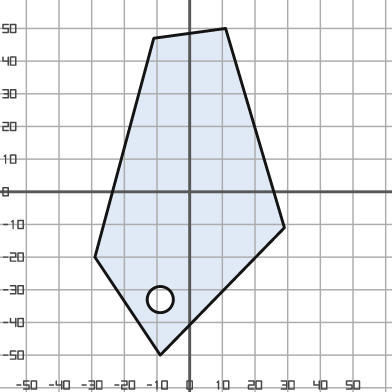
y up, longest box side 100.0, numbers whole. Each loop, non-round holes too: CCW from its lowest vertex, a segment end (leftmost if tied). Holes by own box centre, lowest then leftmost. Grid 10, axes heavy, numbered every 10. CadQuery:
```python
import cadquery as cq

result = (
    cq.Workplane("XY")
    .moveTo(-9.0, -50.0)
    .lineTo(29.0, -11.0)
    .lineTo(11.0, 50.0)
    .lineTo(-11.0, 47.0)
    .lineTo(-29.0, -20.0)
    .close()
    .moveTo(-9.0, -33.0)
    .circle(4.0)
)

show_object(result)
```